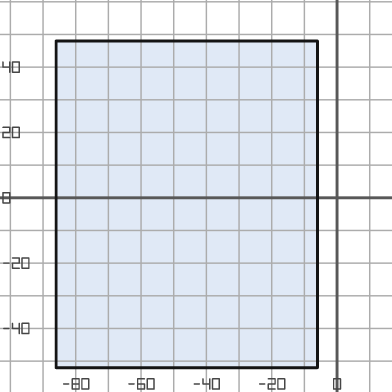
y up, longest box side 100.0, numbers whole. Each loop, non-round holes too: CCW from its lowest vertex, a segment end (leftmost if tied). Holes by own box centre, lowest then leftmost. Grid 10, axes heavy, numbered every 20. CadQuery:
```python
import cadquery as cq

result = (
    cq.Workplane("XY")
    .moveTo(-86.0, -52.0)
    .lineTo(-6.0, -52.0)
    .lineTo(-6.0, 48.0)
    .lineTo(-86.0, 48.0)
    .close()
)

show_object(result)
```